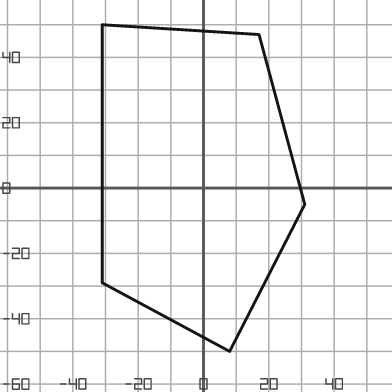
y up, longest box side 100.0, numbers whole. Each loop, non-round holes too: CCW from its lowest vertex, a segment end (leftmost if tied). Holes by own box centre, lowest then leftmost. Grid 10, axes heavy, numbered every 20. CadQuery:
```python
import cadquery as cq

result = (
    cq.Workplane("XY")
    .moveTo(8.0, -50.0)
    .lineTo(31.0, -5.0)
    .lineTo(17.0, 47.0)
    .lineTo(-31.0, 50.0)
    .lineTo(-31.0, -29.0)
    .close()
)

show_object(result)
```